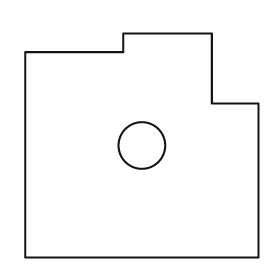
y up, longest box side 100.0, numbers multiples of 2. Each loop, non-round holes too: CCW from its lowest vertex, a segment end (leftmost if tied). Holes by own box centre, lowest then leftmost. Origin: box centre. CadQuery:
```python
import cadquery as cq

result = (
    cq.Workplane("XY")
    .moveTo(-50.0, -48.0)
    .lineTo(50.0, -48.0)
    .lineTo(50.0, 18.0)
    .lineTo(30.0, 18.0)
    .lineTo(30.0, 48.0)
    .lineTo(-8.0, 48.0)
    .lineTo(-8.0, 40.0)
    .lineTo(-50.0, 40.0)
    .close()
    .moveTo(0.0, 0.0)
    .circle(10.0)
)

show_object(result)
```